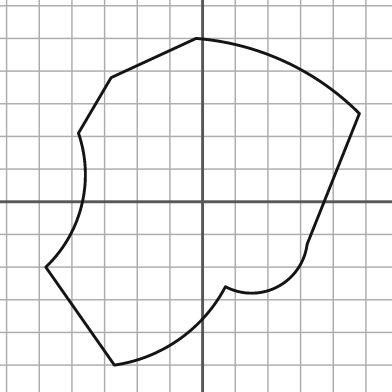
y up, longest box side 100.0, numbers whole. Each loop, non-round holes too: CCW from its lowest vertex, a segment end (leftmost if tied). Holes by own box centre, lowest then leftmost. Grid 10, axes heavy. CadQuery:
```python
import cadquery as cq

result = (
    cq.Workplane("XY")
    .moveTo(-27.0, -50.0)
    .threePointArc((-7.0, -42.0), (7.0, -26.0))
    .threePointArc((23.0, -26.0), (32.0, -13.0))
    .lineTo(48.0, 27.0)
    .threePointArc((25.0, 43.0), (-2.0, 50.0))
    .lineTo(-28.0, 38.0)
    .lineTo(-38.0, 21.0)
    .threePointArc((-37.0, -1.0), (-48.0, -20.0))
    .close()
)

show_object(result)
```